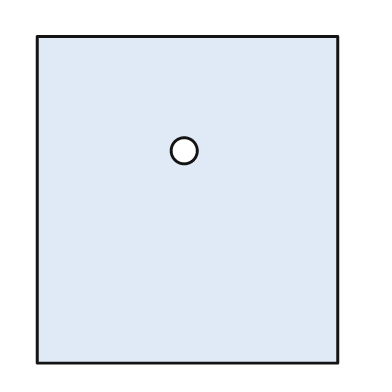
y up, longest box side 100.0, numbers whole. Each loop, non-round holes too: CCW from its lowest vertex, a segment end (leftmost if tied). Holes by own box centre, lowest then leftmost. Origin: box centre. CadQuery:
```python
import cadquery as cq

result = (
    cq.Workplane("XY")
    .moveTo(-46.0, -50.0)
    .lineTo(46.0, -50.0)
    .lineTo(46.0, 50.0)
    .lineTo(-46.0, 50.0)
    .close()
    .moveTo(-1.0, 15.0)
    .circle(4.0)
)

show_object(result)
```